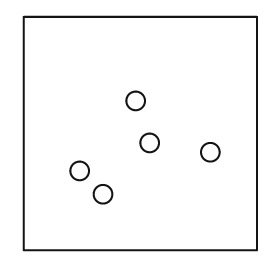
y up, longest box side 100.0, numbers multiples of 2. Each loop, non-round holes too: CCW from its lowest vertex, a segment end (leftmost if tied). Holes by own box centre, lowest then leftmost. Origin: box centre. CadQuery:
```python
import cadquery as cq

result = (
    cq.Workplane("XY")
    .moveTo(-50.0, -50.0)
    .lineTo(50.0, -50.0)
    .lineTo(50.0, 50.0)
    .lineTo(-50.0, 50.0)
    .close()
    .moveTo(-16.0, -26.0)
    .circle(4.0)
    .moveTo(-26.0, -16.0)
    .circle(4.0)
    .moveTo(30.0, -8.0)
    .circle(4.0)
    .moveTo(4.0, -4.0)
    .circle(4.0)
    .moveTo(-2.0, 14.0)
    .circle(4.0)
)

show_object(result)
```